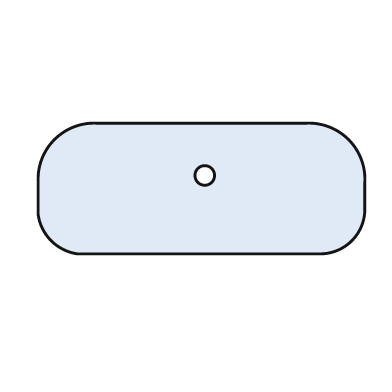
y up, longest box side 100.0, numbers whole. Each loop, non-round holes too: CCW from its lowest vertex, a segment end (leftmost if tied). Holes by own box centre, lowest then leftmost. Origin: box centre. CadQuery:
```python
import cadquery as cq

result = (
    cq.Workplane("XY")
    .moveTo(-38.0, -20.0)
    .lineTo(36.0, -20.0)
    .threePointArc((46.0, -16.0), (50.0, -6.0))
    .lineTo(50.0, 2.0)
    .threePointArc((45.0, 15.0), (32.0, 20.0))
    .lineTo(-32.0, 20.0)
    .threePointArc((-45.0, 15.0), (-50.0, 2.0))
    .lineTo(-50.0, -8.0)
    .threePointArc((-46.0, -16.0), (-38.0, -20.0))
    .close()
    .moveTo(1.0, 4.0)
    .circle(3.0)
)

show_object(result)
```